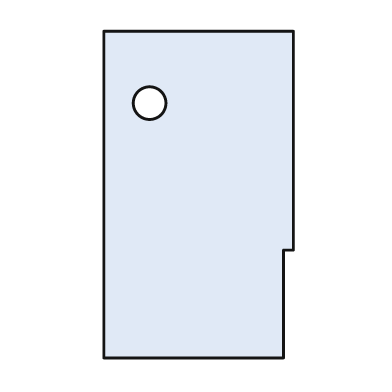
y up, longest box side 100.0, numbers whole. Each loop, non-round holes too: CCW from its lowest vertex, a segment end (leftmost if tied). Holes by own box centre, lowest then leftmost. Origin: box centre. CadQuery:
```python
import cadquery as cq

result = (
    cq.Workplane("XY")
    .moveTo(-29.0, -50.0)
    .lineTo(26.0, -50.0)
    .lineTo(26.0, -17.0)
    .lineTo(29.0, -17.0)
    .lineTo(29.0, 50.0)
    .lineTo(-29.0, 50.0)
    .close()
    .moveTo(-15.0, 28.0)
    .circle(5.0)
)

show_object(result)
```